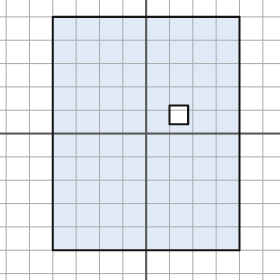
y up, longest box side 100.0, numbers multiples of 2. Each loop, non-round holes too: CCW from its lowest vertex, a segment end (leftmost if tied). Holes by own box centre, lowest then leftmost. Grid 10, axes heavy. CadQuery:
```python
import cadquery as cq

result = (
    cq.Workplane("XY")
    .moveTo(-40.0, -50.0)
    .lineTo(40.0, -50.0)
    .lineTo(40.0, 50.0)
    .lineTo(-40.0, 50.0)
    .close()
    .moveTo(10.0, 4.0)
    .lineTo(18.0, 4.0)
    .lineTo(18.0, 12.0)
    .lineTo(10.0, 12.0)
    .close()
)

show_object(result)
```